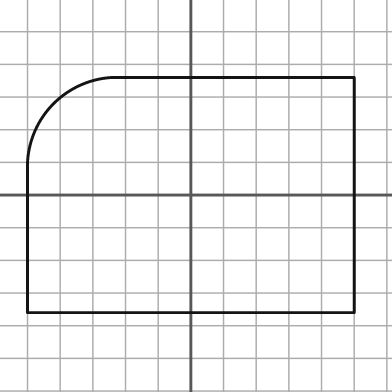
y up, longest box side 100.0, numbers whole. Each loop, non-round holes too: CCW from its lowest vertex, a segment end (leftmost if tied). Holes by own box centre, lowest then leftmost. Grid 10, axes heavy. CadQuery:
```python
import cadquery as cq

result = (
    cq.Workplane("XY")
    .moveTo(-50.0, -36.0)
    .lineTo(50.0, -36.0)
    .lineTo(50.0, 36.0)
    .lineTo(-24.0, 36.0)
    .threePointArc((-42.0, 28.0), (-50.0, 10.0))
    .close()
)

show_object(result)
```